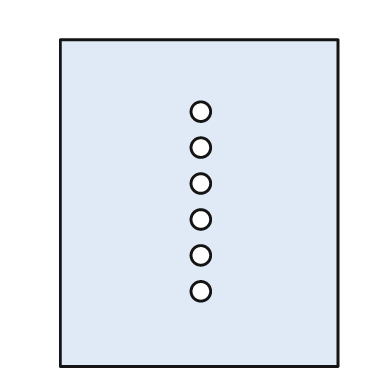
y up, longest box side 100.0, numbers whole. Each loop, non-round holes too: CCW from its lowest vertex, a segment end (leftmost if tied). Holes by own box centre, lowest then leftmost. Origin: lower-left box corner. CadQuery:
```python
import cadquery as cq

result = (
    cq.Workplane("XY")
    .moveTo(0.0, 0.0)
    .lineTo(85.0, 0.0)
    .lineTo(85.0, 100.0)
    .lineTo(0.0, 100.0)
    .close()
    .moveTo(43.0, 23.0)
    .circle(3.0)
    .moveTo(43.0, 34.0)
    .circle(3.0)
    .moveTo(43.0, 45.0)
    .circle(3.0)
    .moveTo(43.0, 56.0)
    .circle(3.0)
    .moveTo(43.0, 67.0)
    .circle(3.0)
    .moveTo(43.0, 78.0)
    .circle(3.0)
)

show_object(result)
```